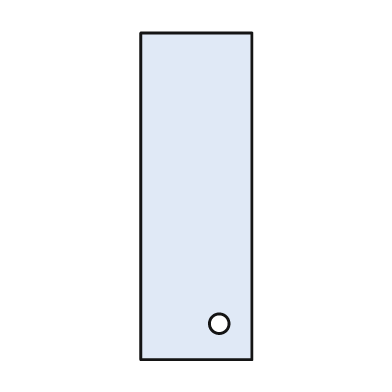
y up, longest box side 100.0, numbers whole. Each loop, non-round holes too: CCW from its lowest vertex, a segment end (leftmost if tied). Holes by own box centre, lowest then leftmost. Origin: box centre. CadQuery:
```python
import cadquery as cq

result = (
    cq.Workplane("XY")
    .moveTo(-17.0, -50.0)
    .lineTo(17.0, -50.0)
    .lineTo(17.0, 50.0)
    .lineTo(-17.0, 50.0)
    .close()
    .moveTo(7.0, -39.0)
    .circle(3.0)
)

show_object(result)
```